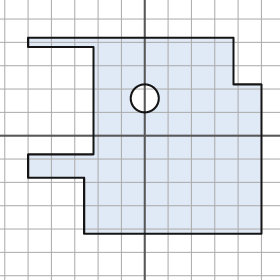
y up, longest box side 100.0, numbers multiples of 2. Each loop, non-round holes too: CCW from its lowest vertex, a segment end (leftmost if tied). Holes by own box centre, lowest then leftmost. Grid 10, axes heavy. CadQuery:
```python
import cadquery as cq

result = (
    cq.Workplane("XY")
    .moveTo(-26.0, -42.0)
    .lineTo(50.0, -42.0)
    .lineTo(50.0, 22.0)
    .lineTo(38.0, 22.0)
    .lineTo(38.0, 42.0)
    .lineTo(-50.0, 42.0)
    .lineTo(-50.0, 38.0)
    .lineTo(-22.0, 38.0)
    .lineTo(-22.0, -8.0)
    .lineTo(-50.0, -8.0)
    .lineTo(-50.0, -18.0)
    .lineTo(-26.0, -18.0)
    .close()
    .moveTo(0.0, 16.0)
    .circle(6.0)
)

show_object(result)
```